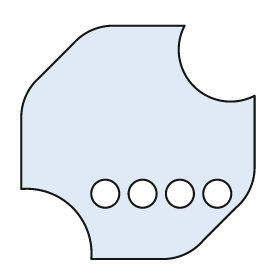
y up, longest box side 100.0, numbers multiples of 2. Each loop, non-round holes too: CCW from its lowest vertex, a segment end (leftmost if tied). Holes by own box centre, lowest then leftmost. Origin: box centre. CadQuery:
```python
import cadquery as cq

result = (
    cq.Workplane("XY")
    .moveTo(-20.0, -50.0)
    .lineTo(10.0, -50.0)
    .threePointArc((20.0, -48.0), (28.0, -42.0))
    .lineTo(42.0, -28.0)
    .threePointArc((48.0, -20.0), (50.0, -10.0))
    .lineTo(50.0, 20.0)
    .threePointArc((24.0, 24.0), (20.0, 50.0))
    .lineTo(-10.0, 50.0)
    .threePointArc((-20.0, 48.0), (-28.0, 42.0))
    .lineTo(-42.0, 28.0)
    .threePointArc((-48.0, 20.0), (-50.0, 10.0))
    .lineTo(-50.0, -20.0)
    .threePointArc((-28.0, -28.0), (-20.0, -50.0))
    .close()
    .moveTo(-14.0, -22.0)
    .circle(6.0)
    .moveTo(2.0, -22.0)
    .circle(6.0)
    .moveTo(18.0, -22.0)
    .circle(6.0)
    .moveTo(34.0, -22.0)
    .circle(6.0)
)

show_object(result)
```